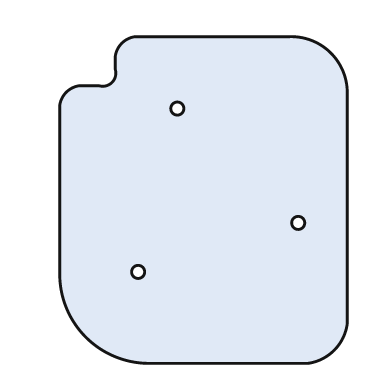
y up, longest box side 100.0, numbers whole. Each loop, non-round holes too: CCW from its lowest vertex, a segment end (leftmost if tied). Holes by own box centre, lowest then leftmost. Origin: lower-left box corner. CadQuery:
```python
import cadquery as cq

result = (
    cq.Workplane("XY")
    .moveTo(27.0, 0.0)
    .lineTo(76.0, 0.0)
    .threePointArc((84.0, 4.0), (88.0, 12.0))
    .lineTo(88.0, 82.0)
    .threePointArc((83.0, 95.0), (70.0, 100.0))
    .lineTo(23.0, 100.0)
    .threePointArc((19.0, 98.0), (17.0, 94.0))
    .lineTo(17.0, 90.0)
    .threePointArc((16.0, 86.0), (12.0, 85.0))
    .lineTo(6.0, 85.0)
    .threePointArc((2.0, 83.0), (0.0, 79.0))
    .lineTo(0.0, 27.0)
    .threePointArc((8.0, 8.0), (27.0, 0.0))
    .close()
    .moveTo(24.0, 28.0)
    .circle(2.0)
    .moveTo(73.0, 43.0)
    .circle(2.0)
    .moveTo(36.0, 78.0)
    .circle(2.0)
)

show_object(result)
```